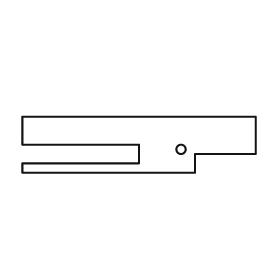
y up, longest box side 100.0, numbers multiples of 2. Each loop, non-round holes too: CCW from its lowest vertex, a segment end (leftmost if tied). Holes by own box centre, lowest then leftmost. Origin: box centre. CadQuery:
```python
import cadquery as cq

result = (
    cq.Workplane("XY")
    .moveTo(-50.0, -12.0)
    .lineTo(24.0, -12.0)
    .lineTo(24.0, -4.0)
    .lineTo(50.0, -4.0)
    .lineTo(50.0, 12.0)
    .lineTo(-50.0, 12.0)
    .lineTo(-50.0, 0.0)
    .lineTo(0.0, 0.0)
    .lineTo(0.0, -8.0)
    .lineTo(-50.0, -8.0)
    .close()
    .moveTo(18.0, -2.0)
    .circle(2.0)
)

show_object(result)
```